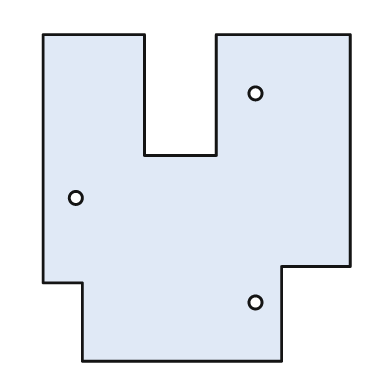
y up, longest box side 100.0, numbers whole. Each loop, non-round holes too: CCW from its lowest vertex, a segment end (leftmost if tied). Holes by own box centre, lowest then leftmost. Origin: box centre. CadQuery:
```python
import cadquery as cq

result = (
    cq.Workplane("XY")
    .moveTo(-35.0, -50.0)
    .lineTo(26.0, -50.0)
    .lineTo(26.0, -21.0)
    .lineTo(47.0, -21.0)
    .lineTo(47.0, 50.0)
    .lineTo(6.0, 50.0)
    .lineTo(6.0, 13.0)
    .lineTo(-16.0, 13.0)
    .lineTo(-16.0, 50.0)
    .lineTo(-47.0, 50.0)
    .lineTo(-47.0, -26.0)
    .lineTo(-35.0, -26.0)
    .close()
    .moveTo(18.0, -32.0)
    .circle(2.0)
    .moveTo(-37.0, 0.0)
    .circle(2.0)
    .moveTo(18.0, 32.0)
    .circle(2.0)
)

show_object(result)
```